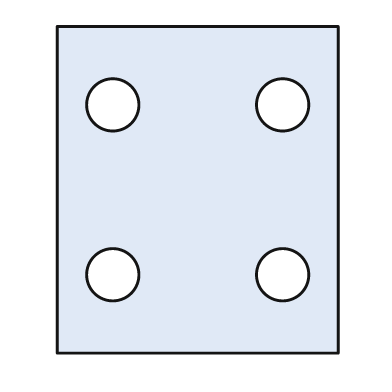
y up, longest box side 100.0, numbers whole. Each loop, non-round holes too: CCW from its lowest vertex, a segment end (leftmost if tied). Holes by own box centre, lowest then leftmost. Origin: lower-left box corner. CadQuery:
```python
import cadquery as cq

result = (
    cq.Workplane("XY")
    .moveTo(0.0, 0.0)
    .lineTo(86.0, 0.0)
    .lineTo(86.0, 100.0)
    .lineTo(0.0, 100.0)
    .close()
    .moveTo(17.0, 24.0)
    .circle(8.0)
    .moveTo(69.0, 24.0)
    .circle(8.0)
    .moveTo(17.0, 76.0)
    .circle(8.0)
    .moveTo(69.0, 76.0)
    .circle(8.0)
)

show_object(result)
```